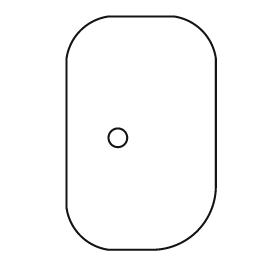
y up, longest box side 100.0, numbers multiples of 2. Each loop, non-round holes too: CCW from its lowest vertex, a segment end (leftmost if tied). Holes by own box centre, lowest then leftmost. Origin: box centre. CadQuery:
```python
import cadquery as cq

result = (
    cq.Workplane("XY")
    .moveTo(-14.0, -50.0)
    .lineTo(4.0, -50.0)
    .threePointArc((24.0, -42.0), (32.0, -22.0))
    .lineTo(32.0, 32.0)
    .threePointArc((26.0, 44.0), (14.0, 50.0))
    .lineTo(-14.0, 50.0)
    .threePointArc((-26.0, 44.0), (-32.0, 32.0))
    .lineTo(-32.0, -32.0)
    .threePointArc((-26.0, -44.0), (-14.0, -50.0))
    .close()
    .moveTo(-10.0, -2.0)
    .circle(4.0)
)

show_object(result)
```